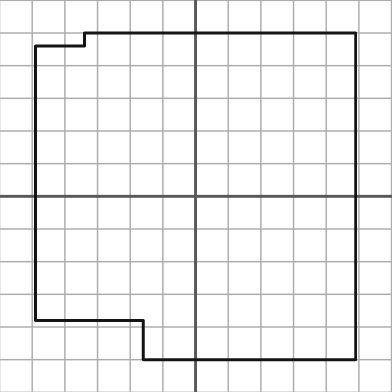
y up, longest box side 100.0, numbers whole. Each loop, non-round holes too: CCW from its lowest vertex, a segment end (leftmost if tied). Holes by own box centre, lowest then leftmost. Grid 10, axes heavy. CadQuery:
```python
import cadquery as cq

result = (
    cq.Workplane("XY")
    .moveTo(-16.0, -50.0)
    .lineTo(49.0, -50.0)
    .lineTo(49.0, 50.0)
    .lineTo(-34.0, 50.0)
    .lineTo(-34.0, 46.0)
    .lineTo(-49.0, 46.0)
    .lineTo(-49.0, -38.0)
    .lineTo(-16.0, -38.0)
    .close()
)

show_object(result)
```